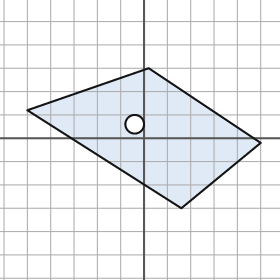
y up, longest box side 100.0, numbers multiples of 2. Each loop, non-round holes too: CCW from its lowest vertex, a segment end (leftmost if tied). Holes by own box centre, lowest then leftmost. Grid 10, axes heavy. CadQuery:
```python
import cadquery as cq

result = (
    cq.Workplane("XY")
    .moveTo(16.0, -30.0)
    .lineTo(50.0, -2.0)
    .lineTo(2.0, 30.0)
    .lineTo(-50.0, 12.0)
    .close()
    .moveTo(-4.0, 6.0)
    .circle(4.0)
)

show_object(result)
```